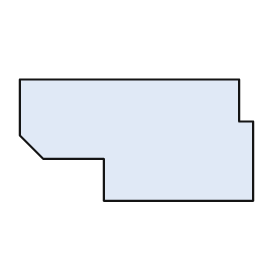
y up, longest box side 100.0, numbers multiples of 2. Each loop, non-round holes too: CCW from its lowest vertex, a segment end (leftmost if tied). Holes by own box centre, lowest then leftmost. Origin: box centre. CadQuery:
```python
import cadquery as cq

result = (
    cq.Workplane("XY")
    .moveTo(-14.0, -26.0)
    .lineTo(50.0, -26.0)
    .lineTo(50.0, 8.0)
    .lineTo(44.0, 8.0)
    .lineTo(44.0, 26.0)
    .lineTo(-50.0, 26.0)
    .lineTo(-50.0, 2.0)
    .lineTo(-40.0, -8.0)
    .lineTo(-14.0, -8.0)
    .close()
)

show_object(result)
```